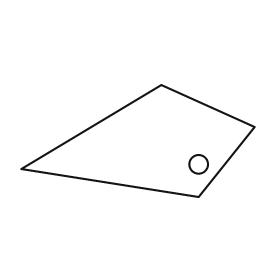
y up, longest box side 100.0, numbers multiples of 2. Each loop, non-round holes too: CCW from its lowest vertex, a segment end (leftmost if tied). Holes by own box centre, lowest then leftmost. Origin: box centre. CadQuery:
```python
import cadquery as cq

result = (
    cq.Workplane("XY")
    .moveTo(26.0, -24.0)
    .lineTo(50.0, 6.0)
    .lineTo(10.0, 24.0)
    .lineTo(-50.0, -12.0)
    .close()
    .moveTo(26.0, -10.0)
    .circle(4.0)
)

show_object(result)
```